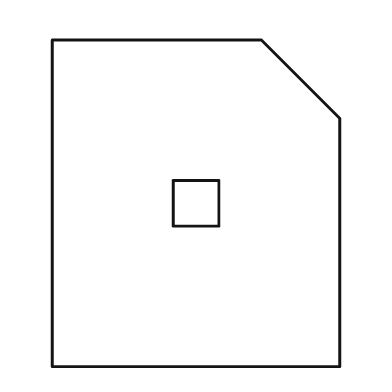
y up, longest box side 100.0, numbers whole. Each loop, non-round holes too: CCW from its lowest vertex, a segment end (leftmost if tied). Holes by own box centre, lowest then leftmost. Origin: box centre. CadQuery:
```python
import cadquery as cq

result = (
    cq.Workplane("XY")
    .moveTo(-44.0, -50.0)
    .lineTo(44.0, -50.0)
    .lineTo(44.0, 26.0)
    .lineTo(20.0, 50.0)
    .lineTo(-44.0, 50.0)
    .close()
    .moveTo(-7.0, -7.0)
    .lineTo(7.0, -7.0)
    .lineTo(7.0, 7.0)
    .lineTo(-7.0, 7.0)
    .close()
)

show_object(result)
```